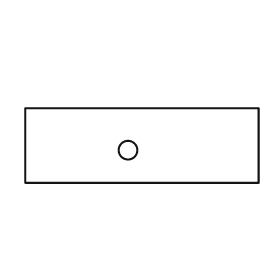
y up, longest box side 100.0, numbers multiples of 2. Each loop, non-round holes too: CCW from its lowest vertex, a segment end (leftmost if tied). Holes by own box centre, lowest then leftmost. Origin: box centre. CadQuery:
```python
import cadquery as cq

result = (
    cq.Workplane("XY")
    .moveTo(-50.0, -16.0)
    .lineTo(50.0, -16.0)
    .lineTo(50.0, 16.0)
    .lineTo(-50.0, 16.0)
    .close()
    .moveTo(-6.0, -2.0)
    .circle(4.0)
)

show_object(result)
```